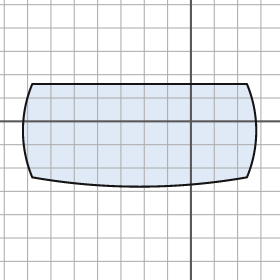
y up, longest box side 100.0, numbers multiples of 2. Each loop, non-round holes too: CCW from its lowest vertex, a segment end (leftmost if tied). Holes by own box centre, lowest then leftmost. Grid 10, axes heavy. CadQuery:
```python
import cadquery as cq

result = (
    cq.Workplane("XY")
    .moveTo(-68.0, -24.0)
    .threePointArc((-22.0, -28.0), (24.0, -24.0))
    .threePointArc((28.0, -4.0), (24.0, 16.0))
    .lineTo(-68.0, 16.0)
    .threePointArc((-72.0, -4.0), (-68.0, -24.0))
    .close()
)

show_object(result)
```